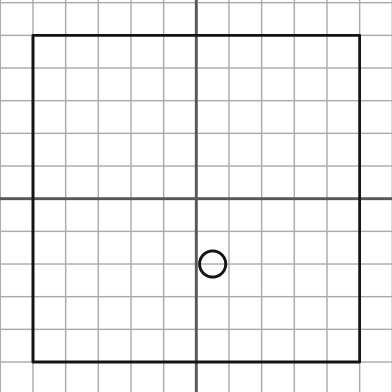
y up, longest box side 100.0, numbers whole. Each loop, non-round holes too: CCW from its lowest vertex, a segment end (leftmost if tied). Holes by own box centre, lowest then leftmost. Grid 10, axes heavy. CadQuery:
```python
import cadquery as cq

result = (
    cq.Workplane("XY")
    .moveTo(-50.0, -50.0)
    .lineTo(50.0, -50.0)
    .lineTo(50.0, 50.0)
    .lineTo(-50.0, 50.0)
    .close()
    .moveTo(5.0, -20.0)
    .circle(4.0)
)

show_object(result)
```